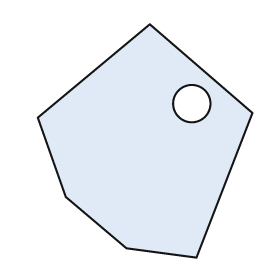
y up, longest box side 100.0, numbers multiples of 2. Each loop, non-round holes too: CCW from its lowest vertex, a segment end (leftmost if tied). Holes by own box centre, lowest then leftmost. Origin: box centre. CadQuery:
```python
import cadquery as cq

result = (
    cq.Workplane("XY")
    .moveTo(22.0, -50.0)
    .lineTo(46.0, 12.0)
    .lineTo(2.0, 50.0)
    .lineTo(-46.0, 10.0)
    .lineTo(-34.0, -24.0)
    .lineTo(-8.0, -46.0)
    .close()
    .moveTo(20.0, 16.0)
    .circle(8.0)
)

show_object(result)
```